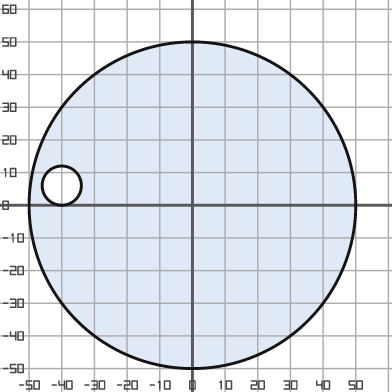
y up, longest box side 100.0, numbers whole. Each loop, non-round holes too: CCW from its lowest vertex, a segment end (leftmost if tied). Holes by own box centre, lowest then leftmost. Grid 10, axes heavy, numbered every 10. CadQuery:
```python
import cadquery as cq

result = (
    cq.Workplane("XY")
    .moveTo(0.0, 0.0)
    .circle(50.0)
    .moveTo(-40.0, 6.0)
    .circle(6.0)
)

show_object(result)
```